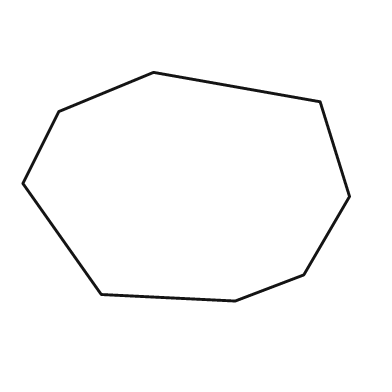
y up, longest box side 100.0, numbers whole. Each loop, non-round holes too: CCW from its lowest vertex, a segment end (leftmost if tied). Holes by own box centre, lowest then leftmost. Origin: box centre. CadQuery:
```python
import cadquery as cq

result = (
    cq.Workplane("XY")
    .moveTo(15.0, -35.0)
    .lineTo(36.0, -27.0)
    .lineTo(50.0, -3.0)
    .lineTo(41.0, 26.0)
    .lineTo(-10.0, 35.0)
    .lineTo(-39.0, 23.0)
    .lineTo(-50.0, 1.0)
    .lineTo(-26.0, -33.0)
    .close()
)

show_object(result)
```